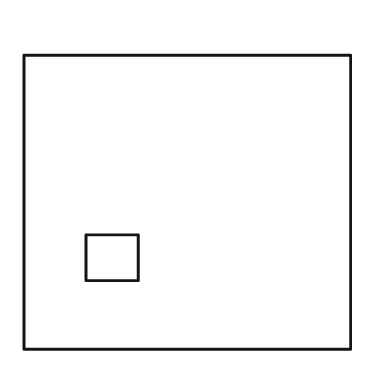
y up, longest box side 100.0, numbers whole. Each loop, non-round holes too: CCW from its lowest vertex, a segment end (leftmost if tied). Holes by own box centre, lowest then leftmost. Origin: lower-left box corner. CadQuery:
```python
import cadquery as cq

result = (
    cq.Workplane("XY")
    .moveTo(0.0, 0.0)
    .lineTo(100.0, 0.0)
    .lineTo(100.0, 90.0)
    .lineTo(0.0, 90.0)
    .close()
    .moveTo(19.0, 21.0)
    .lineTo(35.0, 21.0)
    .lineTo(35.0, 35.0)
    .lineTo(19.0, 35.0)
    .close()
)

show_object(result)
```